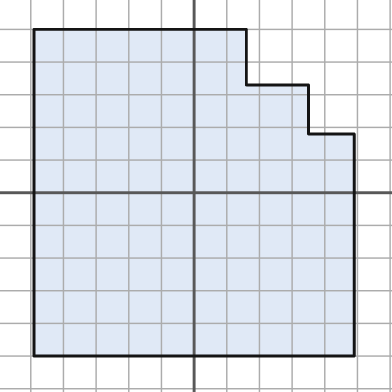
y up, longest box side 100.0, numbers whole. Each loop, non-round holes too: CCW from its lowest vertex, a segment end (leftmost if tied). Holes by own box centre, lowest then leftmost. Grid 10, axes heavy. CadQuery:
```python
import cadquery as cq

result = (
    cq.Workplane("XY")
    .moveTo(-49.0, -50.0)
    .lineTo(49.0, -50.0)
    .lineTo(49.0, 18.0)
    .lineTo(35.0, 18.0)
    .lineTo(35.0, 33.0)
    .lineTo(16.0, 33.0)
    .lineTo(16.0, 50.0)
    .lineTo(-49.0, 50.0)
    .close()
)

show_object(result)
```